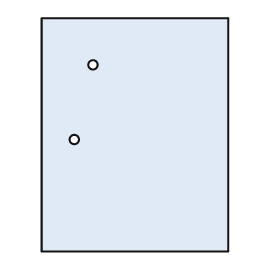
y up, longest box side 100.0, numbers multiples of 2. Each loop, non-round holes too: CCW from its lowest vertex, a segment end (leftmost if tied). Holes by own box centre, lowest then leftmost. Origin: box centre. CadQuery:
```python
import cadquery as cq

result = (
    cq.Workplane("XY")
    .moveTo(-40.0, -50.0)
    .lineTo(40.0, -50.0)
    .lineTo(40.0, 50.0)
    .lineTo(-40.0, 50.0)
    .close()
    .moveTo(-26.0, -2.0)
    .circle(2.0)
    .moveTo(-18.0, 30.0)
    .circle(2.0)
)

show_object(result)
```